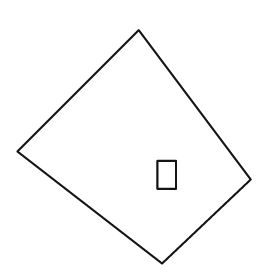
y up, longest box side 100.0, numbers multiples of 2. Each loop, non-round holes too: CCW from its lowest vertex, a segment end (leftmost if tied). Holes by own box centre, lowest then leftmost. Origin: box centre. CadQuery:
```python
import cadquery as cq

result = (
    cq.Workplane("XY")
    .moveTo(12.0, -50.0)
    .lineTo(50.0, -14.0)
    .lineTo(2.0, 50.0)
    .lineTo(-50.0, -2.0)
    .close()
    .moveTo(10.0, -18.0)
    .lineTo(18.0, -18.0)
    .lineTo(18.0, -6.0)
    .lineTo(10.0, -6.0)
    .close()
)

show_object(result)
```